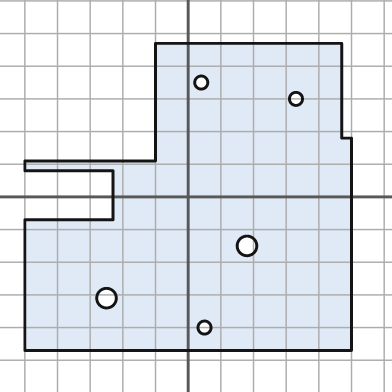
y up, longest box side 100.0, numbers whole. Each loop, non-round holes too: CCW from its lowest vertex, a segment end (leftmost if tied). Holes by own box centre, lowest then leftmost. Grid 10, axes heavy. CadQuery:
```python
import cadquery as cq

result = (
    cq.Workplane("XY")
    .moveTo(-50.0, -47.0)
    .lineTo(50.0, -47.0)
    .lineTo(50.0, 18.0)
    .lineTo(47.0, 18.0)
    .lineTo(47.0, 47.0)
    .lineTo(-10.0, 47.0)
    .lineTo(-10.0, 11.0)
    .lineTo(-50.0, 11.0)
    .lineTo(-50.0, 8.0)
    .lineTo(-23.0, 8.0)
    .lineTo(-23.0, -7.0)
    .lineTo(-50.0, -7.0)
    .close()
    .moveTo(5.0, -40.0)
    .circle(2.0)
    .moveTo(-25.0, -31.0)
    .circle(3.0)
    .moveTo(18.0, -15.0)
    .circle(3.0)
    .moveTo(33.0, 30.0)
    .circle(2.0)
    .moveTo(4.0, 35.0)
    .circle(2.0)
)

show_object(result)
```